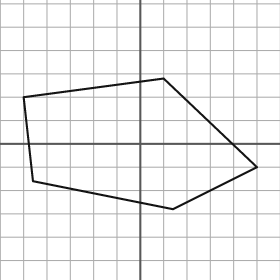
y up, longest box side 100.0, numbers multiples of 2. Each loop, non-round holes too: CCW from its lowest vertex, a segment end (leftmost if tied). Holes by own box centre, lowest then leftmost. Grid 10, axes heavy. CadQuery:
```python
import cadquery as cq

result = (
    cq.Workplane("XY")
    .moveTo(14.0, -28.0)
    .lineTo(50.0, -10.0)
    .lineTo(10.0, 28.0)
    .lineTo(-50.0, 20.0)
    .lineTo(-46.0, -16.0)
    .close()
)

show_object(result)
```